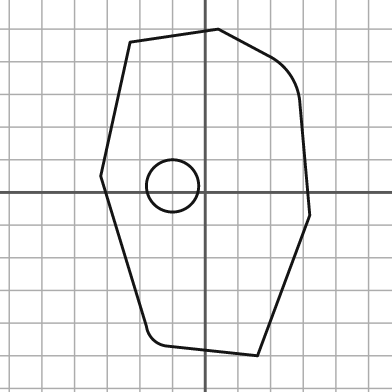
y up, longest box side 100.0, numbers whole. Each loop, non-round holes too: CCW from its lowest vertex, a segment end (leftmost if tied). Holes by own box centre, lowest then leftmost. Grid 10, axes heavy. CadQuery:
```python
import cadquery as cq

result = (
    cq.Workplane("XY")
    .moveTo(16.0, -50.0)
    .lineTo(32.0, -7.0)
    .lineTo(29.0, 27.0)
    .threePointArc((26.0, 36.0), (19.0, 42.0))
    .lineTo(4.0, 50.0)
    .lineTo(-23.0, 46.0)
    .lineTo(-32.0, 5.0)
    .lineTo(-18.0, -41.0)
    .threePointArc((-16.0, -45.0), (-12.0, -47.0))
    .close()
    .moveTo(-10.0, 2.0)
    .circle(8.0)
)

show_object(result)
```